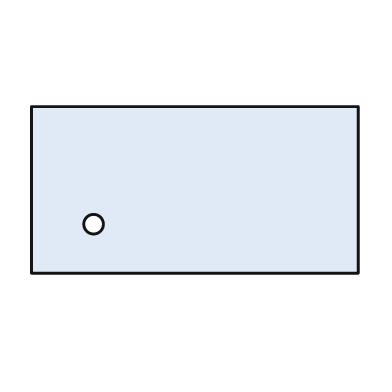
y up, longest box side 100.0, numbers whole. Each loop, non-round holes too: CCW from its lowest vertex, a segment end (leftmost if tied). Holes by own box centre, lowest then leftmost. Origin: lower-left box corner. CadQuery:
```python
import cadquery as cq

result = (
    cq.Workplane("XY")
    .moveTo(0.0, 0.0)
    .lineTo(100.0, 0.0)
    .lineTo(100.0, 51.0)
    .lineTo(0.0, 51.0)
    .close()
    .moveTo(19.0, 15.0)
    .circle(3.0)
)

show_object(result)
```